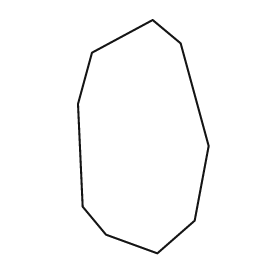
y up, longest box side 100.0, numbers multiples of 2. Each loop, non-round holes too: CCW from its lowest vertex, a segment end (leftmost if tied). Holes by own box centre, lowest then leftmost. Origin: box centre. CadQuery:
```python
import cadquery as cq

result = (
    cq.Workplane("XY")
    .moveTo(6.0, -50.0)
    .lineTo(22.0, -36.0)
    .lineTo(28.0, -4.0)
    .lineTo(16.0, 40.0)
    .lineTo(4.0, 50.0)
    .lineTo(-22.0, 36.0)
    .lineTo(-28.0, 14.0)
    .lineTo(-26.0, -30.0)
    .lineTo(-16.0, -42.0)
    .close()
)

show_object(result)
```